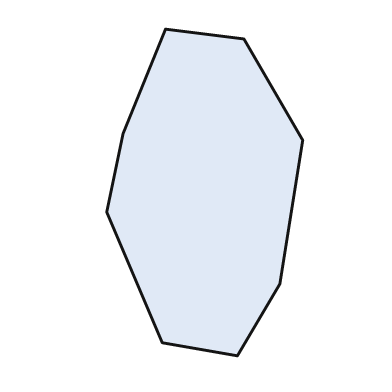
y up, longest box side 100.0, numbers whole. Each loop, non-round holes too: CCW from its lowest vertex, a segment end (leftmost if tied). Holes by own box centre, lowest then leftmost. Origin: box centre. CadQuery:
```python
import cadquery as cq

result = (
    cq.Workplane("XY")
    .moveTo(10.0, -50.0)
    .lineTo(23.0, -28.0)
    .lineTo(30.0, 16.0)
    .lineTo(12.0, 47.0)
    .lineTo(-12.0, 50.0)
    .lineTo(-25.0, 18.0)
    .lineTo(-30.0, -6.0)
    .lineTo(-13.0, -46.0)
    .close()
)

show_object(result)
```